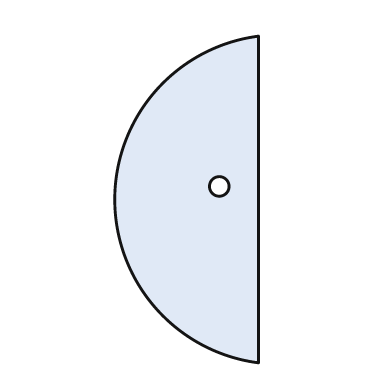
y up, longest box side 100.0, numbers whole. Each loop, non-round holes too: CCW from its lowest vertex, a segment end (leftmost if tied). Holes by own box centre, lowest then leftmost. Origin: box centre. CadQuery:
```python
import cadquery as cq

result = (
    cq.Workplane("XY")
    .moveTo(22.0, -50.0)
    .lineTo(22.0, 50.0)
    .threePointArc((-22.0, 0.0), (22.0, -50.0))
    .close()
    .moveTo(10.0, 4.0)
    .circle(3.0)
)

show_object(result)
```